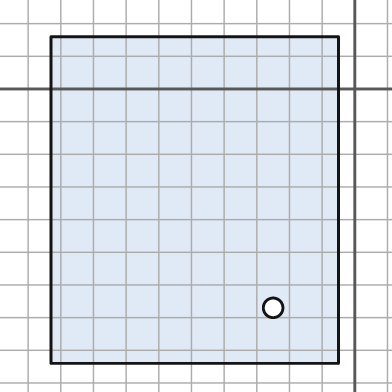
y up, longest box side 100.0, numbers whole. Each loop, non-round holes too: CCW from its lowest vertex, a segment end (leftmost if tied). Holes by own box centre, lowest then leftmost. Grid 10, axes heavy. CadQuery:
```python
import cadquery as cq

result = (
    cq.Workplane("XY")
    .moveTo(-93.0, -84.0)
    .lineTo(-5.0, -84.0)
    .lineTo(-5.0, 16.0)
    .lineTo(-93.0, 16.0)
    .close()
    .moveTo(-25.0, -67.0)
    .circle(3.0)
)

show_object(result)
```